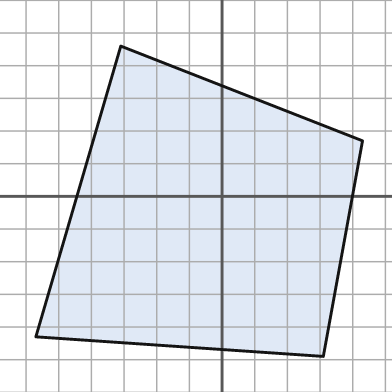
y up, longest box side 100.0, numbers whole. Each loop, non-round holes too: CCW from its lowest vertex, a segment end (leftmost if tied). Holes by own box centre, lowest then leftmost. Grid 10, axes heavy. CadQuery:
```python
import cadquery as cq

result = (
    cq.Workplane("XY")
    .moveTo(31.0, -49.0)
    .lineTo(43.0, 17.0)
    .lineTo(-31.0, 46.0)
    .lineTo(-57.0, -43.0)
    .close()
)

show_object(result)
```